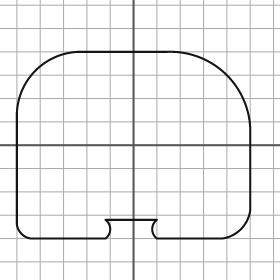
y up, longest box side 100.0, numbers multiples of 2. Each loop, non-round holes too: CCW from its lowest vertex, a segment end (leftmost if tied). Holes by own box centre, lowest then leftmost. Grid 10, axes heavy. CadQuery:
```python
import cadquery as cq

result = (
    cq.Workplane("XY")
    .moveTo(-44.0, -40.0)
    .lineTo(-12.0, -40.0)
    .threePointArc((-10.0, -36.0), (-12.0, -32.0))
    .lineTo(10.0, -32.0)
    .threePointArc((8.0, -36.0), (10.0, -40.0))
    .lineTo(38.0, -40.0)
    .threePointArc((46.0, -36.0), (50.0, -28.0))
    .lineTo(50.0, 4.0)
    .threePointArc((40.0, 30.0), (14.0, 40.0))
    .lineTo(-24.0, 40.0)
    .threePointArc((-42.0, 32.0), (-50.0, 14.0))
    .lineTo(-50.0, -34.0)
    .threePointArc((-48.0, -38.0), (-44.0, -40.0))
    .close()
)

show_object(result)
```